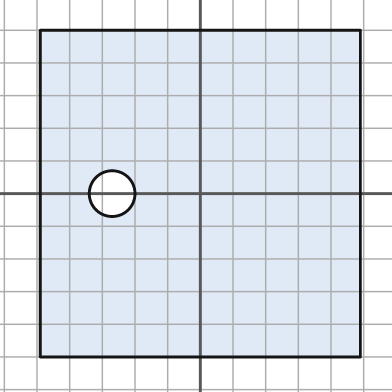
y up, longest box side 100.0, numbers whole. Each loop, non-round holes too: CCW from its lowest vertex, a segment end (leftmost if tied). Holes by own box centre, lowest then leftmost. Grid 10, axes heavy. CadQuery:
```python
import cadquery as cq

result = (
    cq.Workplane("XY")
    .moveTo(-49.0, -50.0)
    .lineTo(49.0, -50.0)
    .lineTo(49.0, 50.0)
    .lineTo(-49.0, 50.0)
    .close()
    .moveTo(-27.0, 0.0)
    .circle(7.0)
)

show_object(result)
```